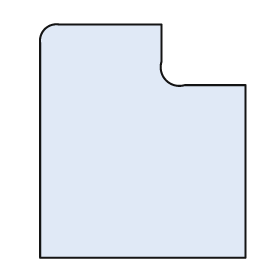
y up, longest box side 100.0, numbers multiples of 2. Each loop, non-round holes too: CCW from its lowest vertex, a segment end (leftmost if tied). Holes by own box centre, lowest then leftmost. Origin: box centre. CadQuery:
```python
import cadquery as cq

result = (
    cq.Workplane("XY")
    .moveTo(-44.0, -50.0)
    .lineTo(44.0, -50.0)
    .lineTo(44.0, 24.0)
    .lineTo(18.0, 24.0)
    .threePointArc((10.0, 26.0), (8.0, 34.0))
    .lineTo(8.0, 50.0)
    .lineTo(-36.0, 50.0)
    .threePointArc((-42.0, 48.0), (-44.0, 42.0))
    .close()
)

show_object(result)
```